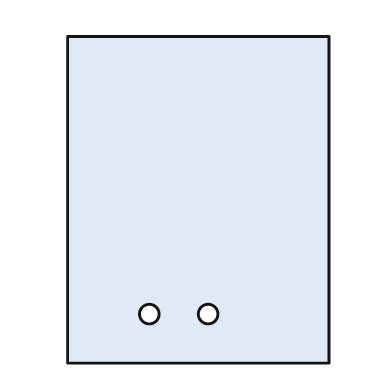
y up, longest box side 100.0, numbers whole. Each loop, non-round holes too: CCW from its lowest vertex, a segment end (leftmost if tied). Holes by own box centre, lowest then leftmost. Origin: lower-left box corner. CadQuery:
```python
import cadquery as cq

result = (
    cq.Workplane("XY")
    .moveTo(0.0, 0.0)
    .lineTo(80.0, 0.0)
    .lineTo(80.0, 100.0)
    .lineTo(0.0, 100.0)
    .close()
    .moveTo(25.0, 15.0)
    .circle(3.0)
    .moveTo(43.0, 15.0)
    .circle(3.0)
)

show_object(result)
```